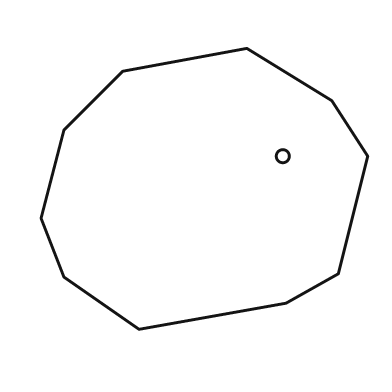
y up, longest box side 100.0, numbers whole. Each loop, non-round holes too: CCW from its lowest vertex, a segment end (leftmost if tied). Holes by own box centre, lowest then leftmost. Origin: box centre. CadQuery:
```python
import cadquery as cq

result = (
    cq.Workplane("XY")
    .moveTo(-20.0, -43.0)
    .lineTo(25.0, -35.0)
    .lineTo(41.0, -26.0)
    .lineTo(50.0, 10.0)
    .lineTo(39.0, 27.0)
    .lineTo(13.0, 43.0)
    .lineTo(-25.0, 36.0)
    .lineTo(-43.0, 18.0)
    .lineTo(-50.0, -9.0)
    .lineTo(-43.0, -27.0)
    .close()
    .moveTo(24.0, 10.0)
    .circle(2.0)
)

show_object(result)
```